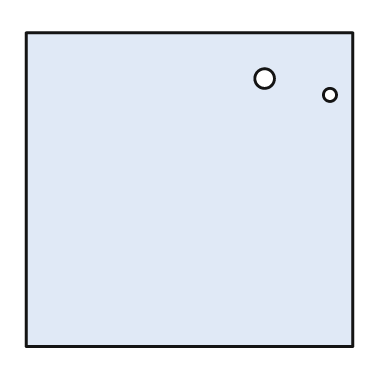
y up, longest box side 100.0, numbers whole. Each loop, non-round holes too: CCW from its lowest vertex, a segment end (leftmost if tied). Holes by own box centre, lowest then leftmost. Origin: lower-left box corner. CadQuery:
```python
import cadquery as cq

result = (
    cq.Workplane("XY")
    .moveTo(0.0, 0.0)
    .lineTo(100.0, 0.0)
    .lineTo(100.0, 96.0)
    .lineTo(0.0, 96.0)
    .close()
    .moveTo(93.0, 77.0)
    .circle(2.0)
    .moveTo(73.0, 82.0)
    .circle(3.0)
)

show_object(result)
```